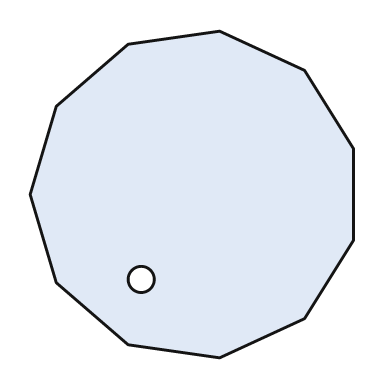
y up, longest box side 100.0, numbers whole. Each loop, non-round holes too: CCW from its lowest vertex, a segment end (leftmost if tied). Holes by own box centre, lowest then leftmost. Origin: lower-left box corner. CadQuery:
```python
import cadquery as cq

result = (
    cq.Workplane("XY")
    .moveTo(58.0, 0.0)
    .lineTo(84.0, 12.0)
    .lineTo(99.0, 36.0)
    .lineTo(99.0, 64.0)
    .lineTo(84.0, 88.0)
    .lineTo(58.0, 100.0)
    .lineTo(30.0, 96.0)
    .lineTo(8.0, 77.0)
    .lineTo(0.0, 50.0)
    .lineTo(8.0, 23.0)
    .lineTo(30.0, 4.0)
    .close()
    .moveTo(34.0, 24.0)
    .circle(4.0)
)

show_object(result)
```